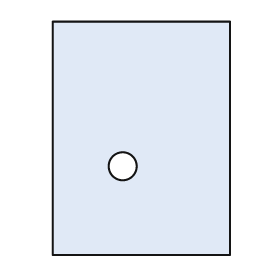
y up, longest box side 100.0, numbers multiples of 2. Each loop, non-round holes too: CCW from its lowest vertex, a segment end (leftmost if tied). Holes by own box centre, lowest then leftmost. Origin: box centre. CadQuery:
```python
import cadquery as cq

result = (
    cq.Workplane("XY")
    .moveTo(-38.0, -50.0)
    .lineTo(38.0, -50.0)
    .lineTo(38.0, 50.0)
    .lineTo(-38.0, 50.0)
    .close()
    .moveTo(-8.0, -12.0)
    .circle(6.0)
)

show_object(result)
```